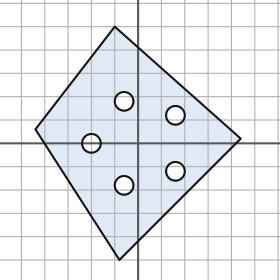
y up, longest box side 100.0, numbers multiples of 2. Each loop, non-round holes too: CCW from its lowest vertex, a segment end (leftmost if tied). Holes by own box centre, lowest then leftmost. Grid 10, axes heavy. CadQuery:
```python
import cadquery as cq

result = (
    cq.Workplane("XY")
    .moveTo(-8.0, -50.0)
    .lineTo(44.0, 2.0)
    .lineTo(-10.0, 50.0)
    .lineTo(-44.0, 6.0)
    .close()
    .moveTo(-6.0, -18.0)
    .circle(4.0)
    .moveTo(16.0, -12.0)
    .circle(4.0)
    .moveTo(-20.0, 0.0)
    .circle(4.0)
    .moveTo(16.0, 12.0)
    .circle(4.0)
    .moveTo(-6.0, 18.0)
    .circle(4.0)
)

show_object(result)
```